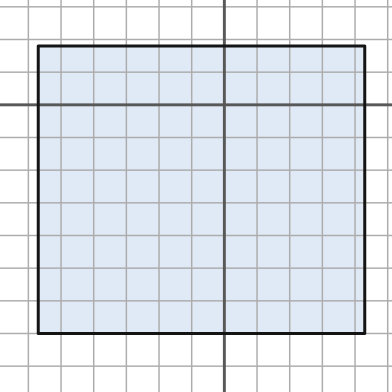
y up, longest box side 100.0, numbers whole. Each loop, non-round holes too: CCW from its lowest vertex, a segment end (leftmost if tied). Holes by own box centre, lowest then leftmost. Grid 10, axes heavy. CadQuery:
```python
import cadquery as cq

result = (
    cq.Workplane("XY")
    .moveTo(-57.0, -70.0)
    .lineTo(43.0, -70.0)
    .lineTo(43.0, 18.0)
    .lineTo(-57.0, 18.0)
    .close()
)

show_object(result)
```